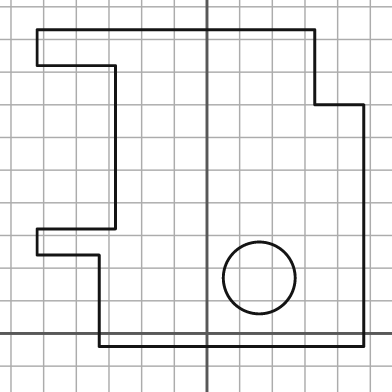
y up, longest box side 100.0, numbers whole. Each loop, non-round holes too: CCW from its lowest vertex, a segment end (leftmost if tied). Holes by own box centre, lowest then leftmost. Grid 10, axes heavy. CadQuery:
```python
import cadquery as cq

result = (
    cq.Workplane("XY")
    .moveTo(-33.0, -4.0)
    .lineTo(48.0, -4.0)
    .lineTo(48.0, 70.0)
    .lineTo(33.0, 70.0)
    .lineTo(33.0, 93.0)
    .lineTo(-52.0, 93.0)
    .lineTo(-52.0, 82.0)
    .lineTo(-28.0, 82.0)
    .lineTo(-28.0, 32.0)
    .lineTo(-52.0, 32.0)
    .lineTo(-52.0, 24.0)
    .lineTo(-33.0, 24.0)
    .close()
    .moveTo(16.0, 17.0)
    .circle(11.0)
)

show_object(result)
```